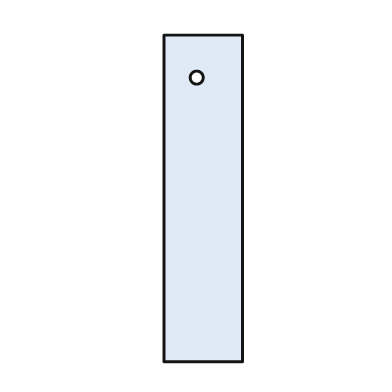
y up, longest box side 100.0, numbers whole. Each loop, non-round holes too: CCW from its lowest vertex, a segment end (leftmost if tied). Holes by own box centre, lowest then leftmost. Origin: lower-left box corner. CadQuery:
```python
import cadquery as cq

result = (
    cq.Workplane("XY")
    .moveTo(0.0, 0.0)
    .lineTo(24.0, 0.0)
    .lineTo(24.0, 100.0)
    .lineTo(0.0, 100.0)
    .close()
    .moveTo(10.0, 87.0)
    .circle(2.0)
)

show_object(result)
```